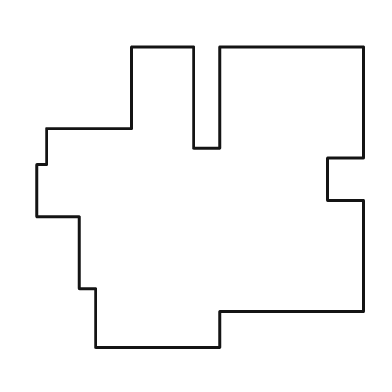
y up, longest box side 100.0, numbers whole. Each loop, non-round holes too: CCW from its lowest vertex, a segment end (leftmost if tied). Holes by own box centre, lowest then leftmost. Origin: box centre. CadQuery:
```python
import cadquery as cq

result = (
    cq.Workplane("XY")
    .moveTo(-32.0, -46.0)
    .lineTo(6.0, -46.0)
    .lineTo(6.0, -35.0)
    .lineTo(50.0, -35.0)
    .lineTo(50.0, -1.0)
    .lineTo(39.0, -1.0)
    .lineTo(39.0, 12.0)
    .lineTo(50.0, 12.0)
    .lineTo(50.0, 46.0)
    .lineTo(6.0, 46.0)
    .lineTo(6.0, 15.0)
    .lineTo(-2.0, 15.0)
    .lineTo(-2.0, 46.0)
    .lineTo(-21.0, 46.0)
    .lineTo(-21.0, 21.0)
    .lineTo(-47.0, 21.0)
    .lineTo(-47.0, 10.0)
    .lineTo(-50.0, 10.0)
    .lineTo(-50.0, -6.0)
    .lineTo(-37.0, -6.0)
    .lineTo(-37.0, -28.0)
    .lineTo(-32.0, -28.0)
    .close()
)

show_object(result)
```